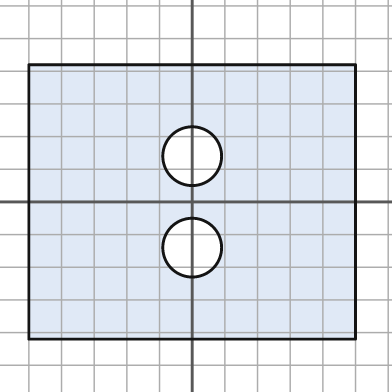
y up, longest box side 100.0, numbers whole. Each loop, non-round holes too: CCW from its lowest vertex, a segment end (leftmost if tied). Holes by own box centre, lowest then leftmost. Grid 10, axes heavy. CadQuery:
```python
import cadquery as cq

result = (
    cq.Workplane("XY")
    .moveTo(-50.0, -42.0)
    .lineTo(50.0, -42.0)
    .lineTo(50.0, 42.0)
    .lineTo(-50.0, 42.0)
    .close()
    .moveTo(0.0, -14.0)
    .circle(9.0)
    .moveTo(0.0, 14.0)
    .circle(9.0)
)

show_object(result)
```